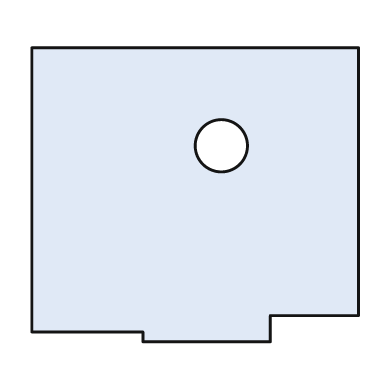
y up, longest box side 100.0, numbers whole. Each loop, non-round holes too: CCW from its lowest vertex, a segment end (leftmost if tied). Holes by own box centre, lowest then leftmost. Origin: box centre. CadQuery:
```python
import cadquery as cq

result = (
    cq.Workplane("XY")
    .moveTo(-16.0, -45.0)
    .lineTo(23.0, -45.0)
    .lineTo(23.0, -37.0)
    .lineTo(50.0, -37.0)
    .lineTo(50.0, 45.0)
    .lineTo(-50.0, 45.0)
    .lineTo(-50.0, -42.0)
    .lineTo(-16.0, -42.0)
    .close()
    .moveTo(8.0, 15.0)
    .circle(8.0)
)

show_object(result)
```